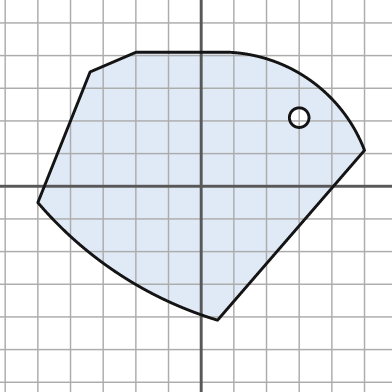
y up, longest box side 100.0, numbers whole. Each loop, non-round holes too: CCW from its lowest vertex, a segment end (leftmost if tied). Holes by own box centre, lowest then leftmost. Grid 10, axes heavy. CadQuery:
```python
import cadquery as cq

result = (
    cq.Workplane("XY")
    .moveTo(5.0, -41.0)
    .lineTo(50.0, 11.0)
    .threePointArc((34.0, 32.0), (9.0, 41.0))
    .lineTo(-20.0, 41.0)
    .lineTo(-34.0, 35.0)
    .lineTo(-50.0, -5.0)
    .threePointArc((-25.0, -27.0), (5.0, -41.0))
    .close()
    .moveTo(30.0, 21.0)
    .circle(3.0)
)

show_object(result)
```